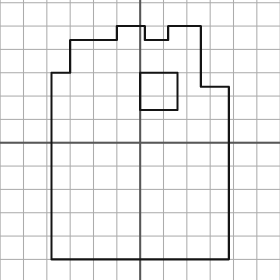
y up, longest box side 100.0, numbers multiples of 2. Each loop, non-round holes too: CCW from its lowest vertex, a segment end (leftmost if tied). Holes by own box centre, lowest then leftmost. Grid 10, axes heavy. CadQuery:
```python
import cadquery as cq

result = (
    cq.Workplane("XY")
    .moveTo(-38.0, -50.0)
    .lineTo(38.0, -50.0)
    .lineTo(38.0, 24.0)
    .lineTo(26.0, 24.0)
    .lineTo(26.0, 50.0)
    .lineTo(12.0, 50.0)
    .lineTo(12.0, 44.0)
    .lineTo(2.0, 44.0)
    .lineTo(2.0, 50.0)
    .lineTo(-10.0, 50.0)
    .lineTo(-10.0, 44.0)
    .lineTo(-30.0, 44.0)
    .lineTo(-30.0, 30.0)
    .lineTo(-38.0, 30.0)
    .close()
    .moveTo(0.0, 14.0)
    .lineTo(16.0, 14.0)
    .lineTo(16.0, 30.0)
    .lineTo(0.0, 30.0)
    .close()
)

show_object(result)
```